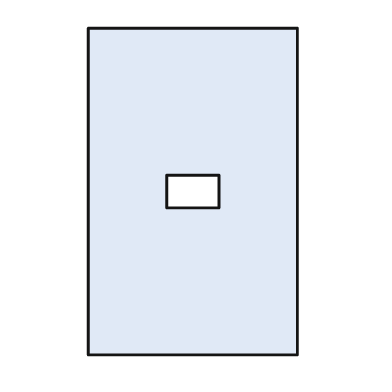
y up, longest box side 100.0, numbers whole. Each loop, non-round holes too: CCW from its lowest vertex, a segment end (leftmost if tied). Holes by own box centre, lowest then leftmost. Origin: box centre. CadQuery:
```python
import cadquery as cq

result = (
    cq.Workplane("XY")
    .moveTo(-32.0, -50.0)
    .lineTo(32.0, -50.0)
    .lineTo(32.0, 50.0)
    .lineTo(-32.0, 50.0)
    .close()
    .moveTo(-8.0, -5.0)
    .lineTo(8.0, -5.0)
    .lineTo(8.0, 5.0)
    .lineTo(-8.0, 5.0)
    .close()
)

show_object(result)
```